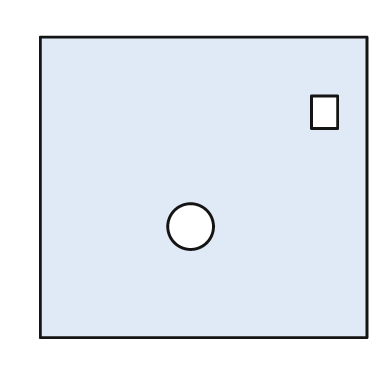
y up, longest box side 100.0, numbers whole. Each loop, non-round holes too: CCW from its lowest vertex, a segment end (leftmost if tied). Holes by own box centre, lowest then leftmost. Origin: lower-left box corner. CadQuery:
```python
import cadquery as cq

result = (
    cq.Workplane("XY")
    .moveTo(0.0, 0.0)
    .lineTo(100.0, 0.0)
    .lineTo(100.0, 92.0)
    .lineTo(0.0, 92.0)
    .close()
    .moveTo(46.0, 34.0)
    .circle(7.0)
    .moveTo(83.0, 64.0)
    .lineTo(91.0, 64.0)
    .lineTo(91.0, 74.0)
    .lineTo(83.0, 74.0)
    .close()
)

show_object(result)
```